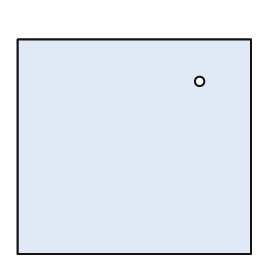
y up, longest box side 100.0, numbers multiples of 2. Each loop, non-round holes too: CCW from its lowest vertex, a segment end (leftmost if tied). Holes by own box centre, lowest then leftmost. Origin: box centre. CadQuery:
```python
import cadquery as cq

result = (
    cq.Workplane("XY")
    .moveTo(-50.0, -46.0)
    .lineTo(50.0, -46.0)
    .lineTo(50.0, 46.0)
    .lineTo(-50.0, 46.0)
    .close()
    .moveTo(28.0, 28.0)
    .circle(2.0)
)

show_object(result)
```